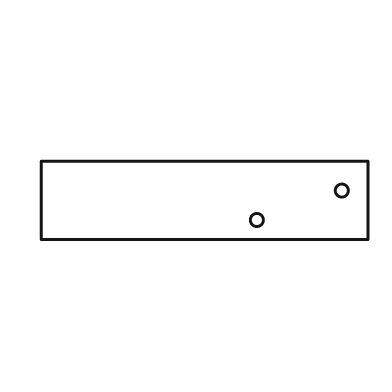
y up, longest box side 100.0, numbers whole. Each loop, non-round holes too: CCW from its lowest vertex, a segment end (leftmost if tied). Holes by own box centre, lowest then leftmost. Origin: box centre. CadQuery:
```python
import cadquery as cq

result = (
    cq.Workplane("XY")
    .moveTo(-50.0, -12.0)
    .lineTo(50.0, -12.0)
    .lineTo(50.0, 12.0)
    .lineTo(-50.0, 12.0)
    .close()
    .moveTo(16.0, -6.0)
    .circle(2.0)
    .moveTo(42.0, 3.0)
    .circle(2.0)
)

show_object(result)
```